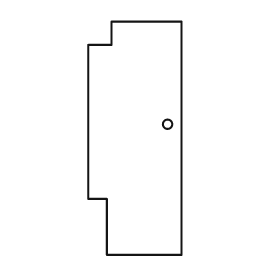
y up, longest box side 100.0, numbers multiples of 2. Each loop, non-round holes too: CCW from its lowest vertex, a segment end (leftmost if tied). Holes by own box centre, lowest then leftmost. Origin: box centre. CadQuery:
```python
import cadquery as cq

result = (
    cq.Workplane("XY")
    .moveTo(-12.0, -50.0)
    .lineTo(20.0, -50.0)
    .lineTo(20.0, 50.0)
    .lineTo(-10.0, 50.0)
    .lineTo(-10.0, 40.0)
    .lineTo(-20.0, 40.0)
    .lineTo(-20.0, -26.0)
    .lineTo(-12.0, -26.0)
    .close()
    .moveTo(14.0, 6.0)
    .circle(2.0)
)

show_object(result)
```